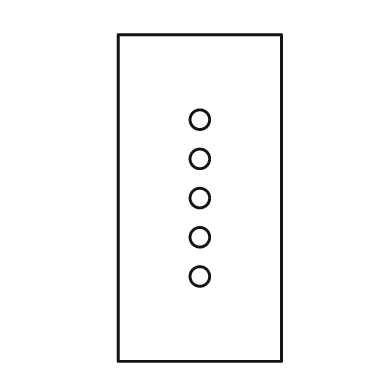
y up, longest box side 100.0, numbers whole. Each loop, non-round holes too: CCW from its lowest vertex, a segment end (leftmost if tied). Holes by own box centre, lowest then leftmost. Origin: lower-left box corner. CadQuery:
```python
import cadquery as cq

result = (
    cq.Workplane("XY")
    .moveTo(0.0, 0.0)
    .lineTo(50.0, 0.0)
    .lineTo(50.0, 100.0)
    .lineTo(0.0, 100.0)
    .close()
    .moveTo(25.0, 26.0)
    .circle(3.0)
    .moveTo(25.0, 38.0)
    .circle(3.0)
    .moveTo(25.0, 50.0)
    .circle(3.0)
    .moveTo(25.0, 62.0)
    .circle(3.0)
    .moveTo(25.0, 74.0)
    .circle(3.0)
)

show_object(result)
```